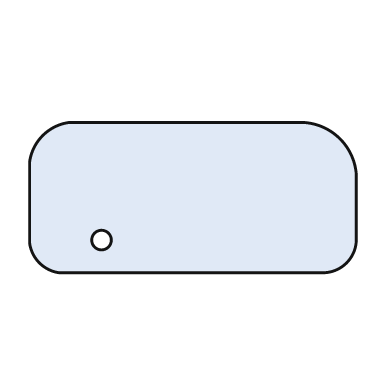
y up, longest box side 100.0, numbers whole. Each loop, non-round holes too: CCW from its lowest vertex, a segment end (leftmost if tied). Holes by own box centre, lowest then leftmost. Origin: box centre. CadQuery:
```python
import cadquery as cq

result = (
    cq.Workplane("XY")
    .moveTo(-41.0, -23.0)
    .lineTo(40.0, -23.0)
    .threePointArc((47.0, -20.0), (50.0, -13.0))
    .lineTo(50.0, 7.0)
    .threePointArc((45.0, 18.0), (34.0, 23.0))
    .lineTo(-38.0, 23.0)
    .threePointArc((-46.0, 19.0), (-50.0, 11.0))
    .lineTo(-50.0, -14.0)
    .threePointArc((-47.0, -20.0), (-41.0, -23.0))
    .close()
    .moveTo(-28.0, -13.0)
    .circle(3.0)
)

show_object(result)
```